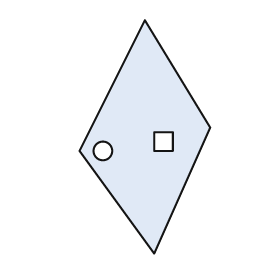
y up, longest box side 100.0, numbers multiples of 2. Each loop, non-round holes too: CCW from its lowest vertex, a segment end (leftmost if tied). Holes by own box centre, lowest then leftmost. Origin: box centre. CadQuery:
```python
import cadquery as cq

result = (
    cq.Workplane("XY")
    .moveTo(4.0, -50.0)
    .lineTo(28.0, 4.0)
    .lineTo(0.0, 50.0)
    .lineTo(-28.0, -6.0)
    .close()
    .moveTo(-18.0, -6.0)
    .circle(4.0)
    .moveTo(4.0, -6.0)
    .lineTo(12.0, -6.0)
    .lineTo(12.0, 2.0)
    .lineTo(4.0, 2.0)
    .close()
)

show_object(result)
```